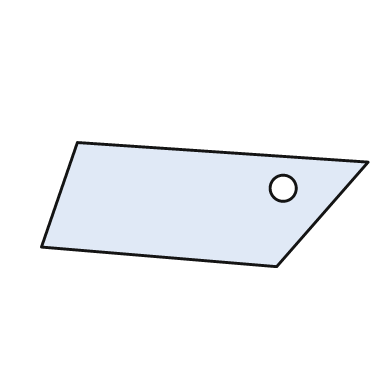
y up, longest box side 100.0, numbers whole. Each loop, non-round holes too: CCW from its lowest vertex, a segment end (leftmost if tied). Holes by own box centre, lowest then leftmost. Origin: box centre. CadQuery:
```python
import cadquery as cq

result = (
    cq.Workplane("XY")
    .moveTo(22.0, -19.0)
    .lineTo(50.0, 13.0)
    .lineTo(-39.0, 19.0)
    .lineTo(-50.0, -13.0)
    .close()
    .moveTo(24.0, 5.0)
    .circle(4.0)
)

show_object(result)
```